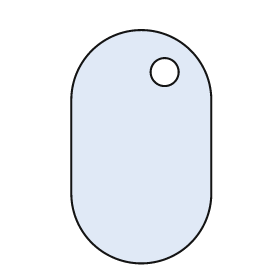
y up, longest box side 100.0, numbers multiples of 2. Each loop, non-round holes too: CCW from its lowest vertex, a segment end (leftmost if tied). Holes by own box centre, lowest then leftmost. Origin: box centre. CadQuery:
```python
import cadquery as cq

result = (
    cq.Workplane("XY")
    .moveTo(-30.0, -20.0)
    .threePointArc((0.0, -50.0), (30.0, -20.0))
    .lineTo(30.0, 20.0)
    .threePointArc((0.0, 50.0), (-30.0, 20.0))
    .close()
    .moveTo(10.0, 32.0)
    .circle(6.0)
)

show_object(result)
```